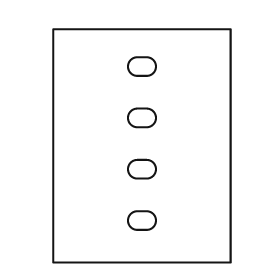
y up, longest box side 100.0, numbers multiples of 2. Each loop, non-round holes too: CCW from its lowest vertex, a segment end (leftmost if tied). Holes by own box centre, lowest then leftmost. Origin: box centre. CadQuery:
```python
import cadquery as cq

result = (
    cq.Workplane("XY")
    .moveTo(-38.0, -50.0)
    .lineTo(38.0, -50.0)
    .lineTo(38.0, 50.0)
    .lineTo(-38.0, 50.0)
    .close()
    .moveTo(-2.0, -36.0)
    .lineTo(2.0, -36.0)
    .threePointArc((6.0, -32.0), (2.0, -28.0))
    .lineTo(-2.0, -28.0)
    .threePointArc((-6.0, -32.0), (-2.0, -36.0))
    .close()
    .moveTo(-2.0, -14.0)
    .lineTo(2.0, -14.0)
    .threePointArc((6.0, -10.0), (2.0, -6.0))
    .lineTo(-2.0, -6.0)
    .threePointArc((-6.0, -10.0), (-2.0, -14.0))
    .close()
    .moveTo(-2.0, 8.0)
    .lineTo(2.0, 8.0)
    .threePointArc((6.0, 12.0), (2.0, 16.0))
    .lineTo(-2.0, 16.0)
    .threePointArc((-6.0, 12.0), (-2.0, 8.0))
    .close()
    .moveTo(-2.0, 30.0)
    .lineTo(2.0, 30.0)
    .threePointArc((6.0, 34.0), (2.0, 38.0))
    .lineTo(-2.0, 38.0)
    .threePointArc((-6.0, 34.0), (-2.0, 30.0))
    .close()
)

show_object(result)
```